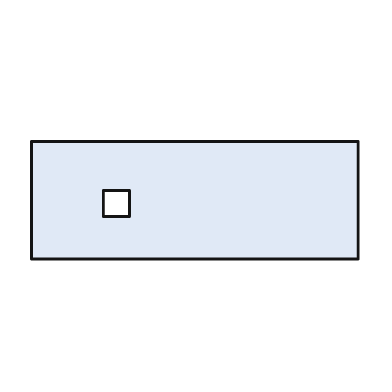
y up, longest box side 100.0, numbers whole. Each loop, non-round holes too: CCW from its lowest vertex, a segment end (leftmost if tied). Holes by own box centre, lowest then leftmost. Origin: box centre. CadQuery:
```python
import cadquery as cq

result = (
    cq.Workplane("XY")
    .moveTo(-50.0, -18.0)
    .lineTo(50.0, -18.0)
    .lineTo(50.0, 18.0)
    .lineTo(-50.0, 18.0)
    .close()
    .moveTo(-28.0, -5.0)
    .lineTo(-20.0, -5.0)
    .lineTo(-20.0, 3.0)
    .lineTo(-28.0, 3.0)
    .close()
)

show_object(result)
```